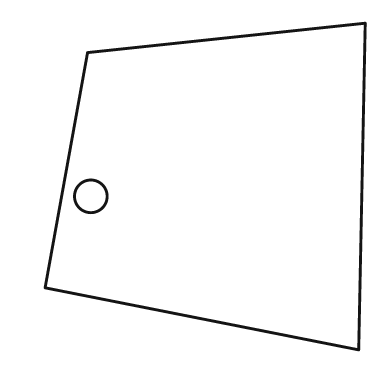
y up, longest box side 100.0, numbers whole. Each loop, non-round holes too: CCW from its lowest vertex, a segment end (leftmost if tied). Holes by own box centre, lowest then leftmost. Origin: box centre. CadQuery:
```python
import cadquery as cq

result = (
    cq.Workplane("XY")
    .moveTo(47.0, -50.0)
    .lineTo(49.0, 50.0)
    .lineTo(-36.0, 41.0)
    .lineTo(-49.0, -31.0)
    .close()
    .moveTo(-35.0, -3.0)
    .circle(5.0)
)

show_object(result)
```